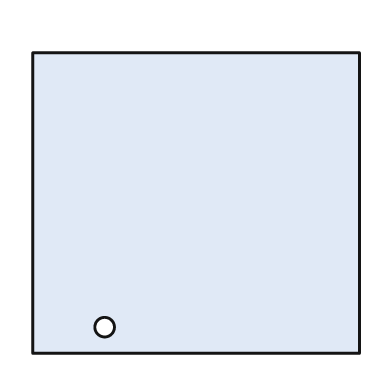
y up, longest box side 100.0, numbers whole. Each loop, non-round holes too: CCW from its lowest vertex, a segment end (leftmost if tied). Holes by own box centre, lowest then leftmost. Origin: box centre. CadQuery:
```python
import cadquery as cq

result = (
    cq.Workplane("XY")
    .moveTo(-50.0, -46.0)
    .lineTo(50.0, -46.0)
    .lineTo(50.0, 46.0)
    .lineTo(-50.0, 46.0)
    .close()
    .moveTo(-28.0, -38.0)
    .circle(3.0)
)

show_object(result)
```